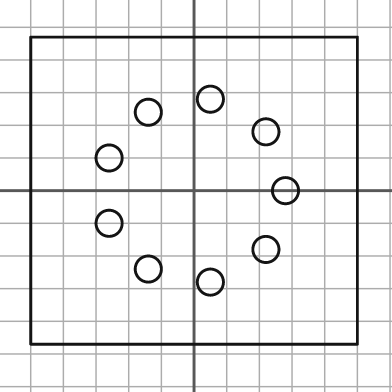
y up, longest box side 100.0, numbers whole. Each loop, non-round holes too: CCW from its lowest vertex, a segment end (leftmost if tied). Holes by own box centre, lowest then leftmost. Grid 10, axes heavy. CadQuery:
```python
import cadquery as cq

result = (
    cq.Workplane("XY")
    .moveTo(-50.0, -47.0)
    .lineTo(50.0, -47.0)
    .lineTo(50.0, 47.0)
    .lineTo(-50.0, 47.0)
    .close()
    .moveTo(5.0, -28.0)
    .circle(4.0)
    .moveTo(-14.0, -24.0)
    .circle(4.0)
    .moveTo(22.0, -18.0)
    .circle(4.0)
    .moveTo(-26.0, -10.0)
    .circle(4.0)
    .moveTo(28.0, 0.0)
    .circle(4.0)
    .moveTo(-26.0, 10.0)
    .circle(4.0)
    .moveTo(22.0, 18.0)
    .circle(4.0)
    .moveTo(-14.0, 24.0)
    .circle(4.0)
    .moveTo(5.0, 28.0)
    .circle(4.0)
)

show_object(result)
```